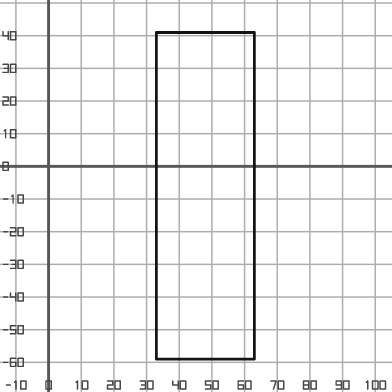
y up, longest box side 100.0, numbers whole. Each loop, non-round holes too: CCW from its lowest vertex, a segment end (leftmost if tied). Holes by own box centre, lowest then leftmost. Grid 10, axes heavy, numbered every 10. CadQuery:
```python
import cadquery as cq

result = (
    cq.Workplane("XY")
    .moveTo(33.0, -59.0)
    .lineTo(63.0, -59.0)
    .lineTo(63.0, 41.0)
    .lineTo(33.0, 41.0)
    .close()
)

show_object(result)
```